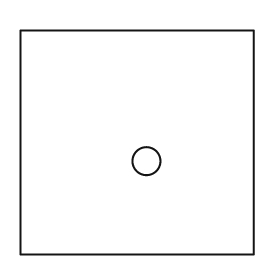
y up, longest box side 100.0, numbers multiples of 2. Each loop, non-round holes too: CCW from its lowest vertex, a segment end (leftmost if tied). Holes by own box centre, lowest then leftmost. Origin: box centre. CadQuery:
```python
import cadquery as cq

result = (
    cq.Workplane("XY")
    .moveTo(-50.0, -48.0)
    .lineTo(50.0, -48.0)
    .lineTo(50.0, 48.0)
    .lineTo(-50.0, 48.0)
    .close()
    .moveTo(4.0, -8.0)
    .circle(6.0)
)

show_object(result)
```